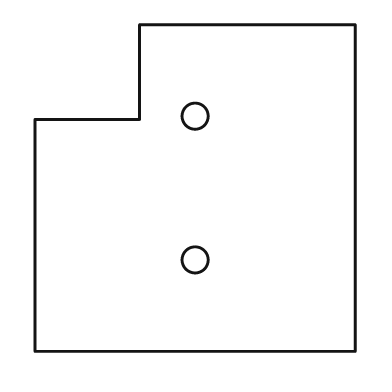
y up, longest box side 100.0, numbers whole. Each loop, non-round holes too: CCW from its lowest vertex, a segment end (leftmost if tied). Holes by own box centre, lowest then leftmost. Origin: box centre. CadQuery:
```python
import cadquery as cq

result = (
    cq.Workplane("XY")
    .moveTo(-49.0, -50.0)
    .lineTo(49.0, -50.0)
    .lineTo(49.0, 50.0)
    .lineTo(-17.0, 50.0)
    .lineTo(-17.0, 21.0)
    .lineTo(-49.0, 21.0)
    .close()
    .moveTo(0.0, -22.0)
    .circle(4.0)
    .moveTo(0.0, 22.0)
    .circle(4.0)
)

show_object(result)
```